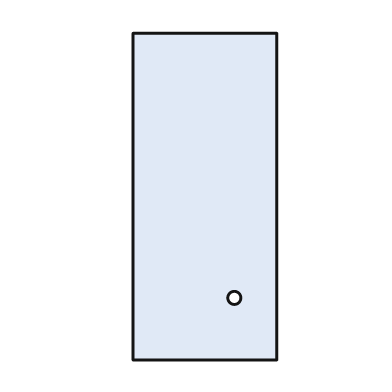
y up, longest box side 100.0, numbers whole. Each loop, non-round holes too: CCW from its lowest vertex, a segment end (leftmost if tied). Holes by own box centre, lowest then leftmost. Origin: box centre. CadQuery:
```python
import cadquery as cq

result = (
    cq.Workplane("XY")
    .moveTo(-22.0, -50.0)
    .lineTo(22.0, -50.0)
    .lineTo(22.0, 50.0)
    .lineTo(-22.0, 50.0)
    .close()
    .moveTo(9.0, -31.0)
    .circle(2.0)
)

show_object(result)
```